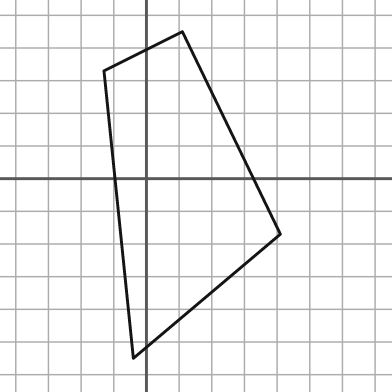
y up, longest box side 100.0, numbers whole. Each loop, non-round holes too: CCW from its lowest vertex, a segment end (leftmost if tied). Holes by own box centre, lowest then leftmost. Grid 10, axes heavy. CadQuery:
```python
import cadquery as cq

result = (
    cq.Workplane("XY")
    .moveTo(-4.0, -55.0)
    .lineTo(41.0, -17.0)
    .lineTo(11.0, 45.0)
    .lineTo(-13.0, 33.0)
    .close()
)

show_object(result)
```